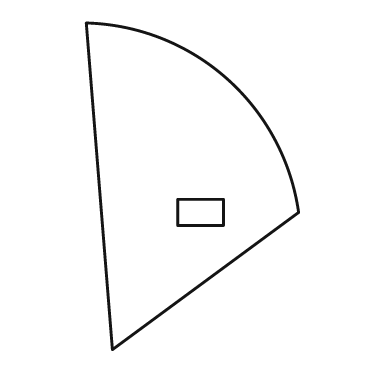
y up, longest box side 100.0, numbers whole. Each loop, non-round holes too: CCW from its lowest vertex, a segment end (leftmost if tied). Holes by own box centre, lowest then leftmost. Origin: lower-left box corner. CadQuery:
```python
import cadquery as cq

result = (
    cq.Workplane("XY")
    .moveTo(8.0, 0.0)
    .lineTo(65.0, 42.0)
    .threePointArc((43.0, 83.0), (0.0, 100.0))
    .close()
    .moveTo(28.0, 38.0)
    .lineTo(42.0, 38.0)
    .lineTo(42.0, 46.0)
    .lineTo(28.0, 46.0)
    .close()
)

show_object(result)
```